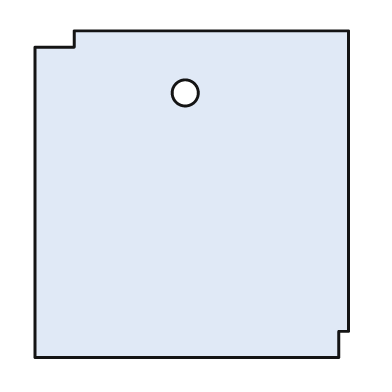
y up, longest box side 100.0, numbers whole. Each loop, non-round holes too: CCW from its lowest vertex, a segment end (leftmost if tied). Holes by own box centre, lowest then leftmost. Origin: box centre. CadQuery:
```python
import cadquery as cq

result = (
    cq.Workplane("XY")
    .moveTo(-48.0, -50.0)
    .lineTo(45.0, -50.0)
    .lineTo(45.0, -42.0)
    .lineTo(48.0, -42.0)
    .lineTo(48.0, 50.0)
    .lineTo(-36.0, 50.0)
    .lineTo(-36.0, 45.0)
    .lineTo(-48.0, 45.0)
    .close()
    .moveTo(-2.0, 31.0)
    .circle(4.0)
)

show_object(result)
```